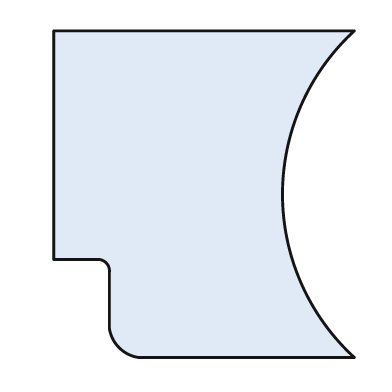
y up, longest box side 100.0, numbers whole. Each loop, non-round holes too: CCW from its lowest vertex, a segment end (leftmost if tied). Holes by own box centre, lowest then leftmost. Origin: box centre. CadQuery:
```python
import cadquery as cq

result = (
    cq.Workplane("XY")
    .moveTo(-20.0, -50.0)
    .lineTo(46.0, -50.0)
    .threePointArc((24.0, 0.0), (46.0, 50.0))
    .lineTo(-46.0, 50.0)
    .lineTo(-46.0, -20.0)
    .lineTo(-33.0, -20.0)
    .threePointArc((-30.0, -21.0), (-29.0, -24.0))
    .lineTo(-29.0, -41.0)
    .threePointArc((-26.0, -47.0), (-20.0, -50.0))
    .close()
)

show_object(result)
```